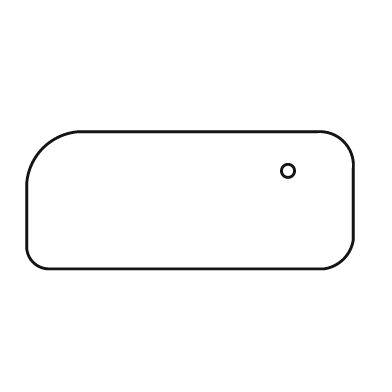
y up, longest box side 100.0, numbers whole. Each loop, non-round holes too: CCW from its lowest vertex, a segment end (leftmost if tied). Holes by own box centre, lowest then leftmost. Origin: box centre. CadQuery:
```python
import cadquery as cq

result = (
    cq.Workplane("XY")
    .moveTo(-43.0, -21.0)
    .lineTo(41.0, -21.0)
    .threePointArc((47.0, -18.0), (50.0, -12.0))
    .lineTo(50.0, 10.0)
    .threePointArc((47.0, 18.0), (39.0, 21.0))
    .lineTo(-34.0, 21.0)
    .threePointArc((-45.0, 16.0), (-50.0, 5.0))
    .lineTo(-50.0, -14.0)
    .threePointArc((-48.0, -19.0), (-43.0, -21.0))
    .close()
    .moveTo(30.0, 9.0)
    .circle(2.0)
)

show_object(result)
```